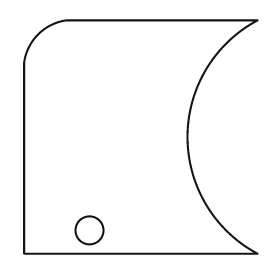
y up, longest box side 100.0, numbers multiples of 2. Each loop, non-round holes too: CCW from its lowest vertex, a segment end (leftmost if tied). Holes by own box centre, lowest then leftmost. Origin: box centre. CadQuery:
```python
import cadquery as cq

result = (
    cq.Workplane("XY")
    .moveTo(-50.0, -50.0)
    .lineTo(50.0, -50.0)
    .threePointArc((20.0, 0.0), (50.0, 50.0))
    .lineTo(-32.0, 50.0)
    .threePointArc((-44.0, 44.0), (-50.0, 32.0))
    .close()
    .moveTo(-22.0, -40.0)
    .circle(6.0)
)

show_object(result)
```